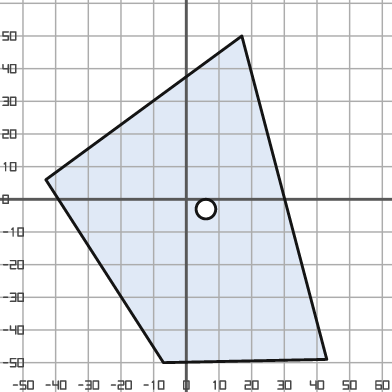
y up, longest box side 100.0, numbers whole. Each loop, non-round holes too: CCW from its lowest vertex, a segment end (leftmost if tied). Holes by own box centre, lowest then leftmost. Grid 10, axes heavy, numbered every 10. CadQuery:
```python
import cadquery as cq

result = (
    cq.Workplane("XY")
    .moveTo(-7.0, -50.0)
    .lineTo(43.0, -49.0)
    .lineTo(17.0, 50.0)
    .lineTo(-43.0, 6.0)
    .close()
    .moveTo(6.0, -3.0)
    .circle(3.0)
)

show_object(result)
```